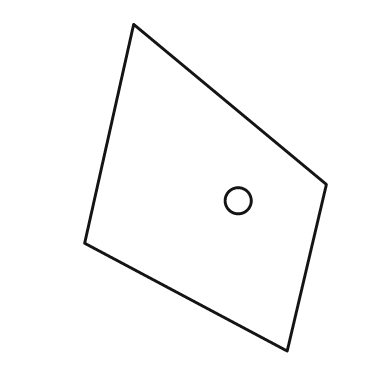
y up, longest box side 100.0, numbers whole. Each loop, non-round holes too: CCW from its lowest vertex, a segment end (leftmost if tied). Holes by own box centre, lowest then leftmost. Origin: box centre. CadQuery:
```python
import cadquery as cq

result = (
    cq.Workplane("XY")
    .moveTo(25.0, -50.0)
    .lineTo(37.0, 1.0)
    .lineTo(-22.0, 50.0)
    .lineTo(-37.0, -17.0)
    .close()
    .moveTo(10.0, -4.0)
    .circle(4.0)
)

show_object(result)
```